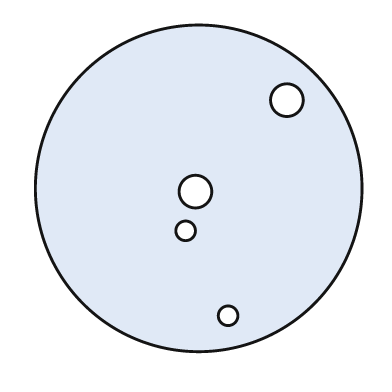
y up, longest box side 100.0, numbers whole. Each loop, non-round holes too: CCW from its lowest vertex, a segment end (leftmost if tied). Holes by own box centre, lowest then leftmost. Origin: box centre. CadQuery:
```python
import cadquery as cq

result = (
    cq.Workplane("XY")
    .moveTo(0.0, 0.0)
    .circle(50.0)
    .moveTo(9.0, -39.0)
    .circle(3.0)
    .moveTo(-4.0, -13.0)
    .circle(3.0)
    .moveTo(-1.0, -1.0)
    .circle(5.0)
    .moveTo(27.0, 27.0)
    .circle(5.0)
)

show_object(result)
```